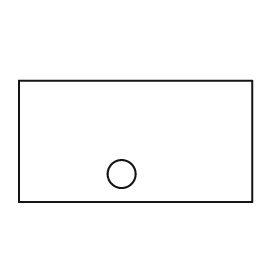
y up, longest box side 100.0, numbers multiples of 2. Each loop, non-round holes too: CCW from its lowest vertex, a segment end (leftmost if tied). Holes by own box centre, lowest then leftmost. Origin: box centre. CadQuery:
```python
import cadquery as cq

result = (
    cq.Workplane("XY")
    .moveTo(-50.0, -26.0)
    .lineTo(50.0, -26.0)
    .lineTo(50.0, 26.0)
    .lineTo(-50.0, 26.0)
    .close()
    .moveTo(-6.0, -14.0)
    .circle(6.0)
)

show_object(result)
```